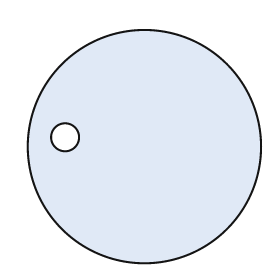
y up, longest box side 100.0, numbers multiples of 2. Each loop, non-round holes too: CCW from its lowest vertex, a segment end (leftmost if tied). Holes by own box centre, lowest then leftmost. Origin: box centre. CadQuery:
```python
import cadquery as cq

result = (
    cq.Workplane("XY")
    .moveTo(0.0, 0.0)
    .circle(50.0)
    .moveTo(-34.0, 4.0)
    .circle(6.0)
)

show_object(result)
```